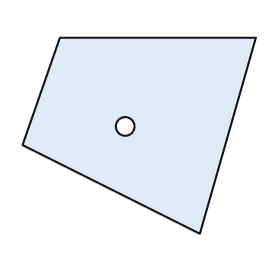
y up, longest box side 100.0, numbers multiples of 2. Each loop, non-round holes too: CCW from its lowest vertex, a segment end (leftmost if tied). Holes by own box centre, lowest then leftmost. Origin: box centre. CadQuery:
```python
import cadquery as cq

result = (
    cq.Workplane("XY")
    .moveTo(26.0, -42.0)
    .lineTo(50.0, 42.0)
    .lineTo(-34.0, 42.0)
    .lineTo(-50.0, -4.0)
    .close()
    .moveTo(-6.0, 4.0)
    .circle(4.0)
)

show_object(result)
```